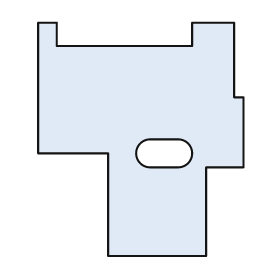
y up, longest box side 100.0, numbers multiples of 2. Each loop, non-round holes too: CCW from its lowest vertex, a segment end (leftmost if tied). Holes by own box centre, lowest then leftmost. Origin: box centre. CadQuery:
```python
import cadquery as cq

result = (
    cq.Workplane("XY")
    .moveTo(-14.0, -50.0)
    .lineTo(28.0, -50.0)
    .lineTo(28.0, -12.0)
    .lineTo(44.0, -12.0)
    .lineTo(44.0, 18.0)
    .lineTo(40.0, 18.0)
    .lineTo(40.0, 50.0)
    .lineTo(22.0, 50.0)
    .lineTo(22.0, 40.0)
    .lineTo(-36.0, 40.0)
    .lineTo(-36.0, 50.0)
    .lineTo(-44.0, 50.0)
    .lineTo(-44.0, -6.0)
    .lineTo(-14.0, -6.0)
    .close()
    .moveTo(4.0, -12.0)
    .lineTo(16.0, -12.0)
    .threePointArc((22.0, -6.0), (16.0, 0.0))
    .lineTo(4.0, 0.0)
    .threePointArc((-2.0, -6.0), (4.0, -12.0))
    .close()
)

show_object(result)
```